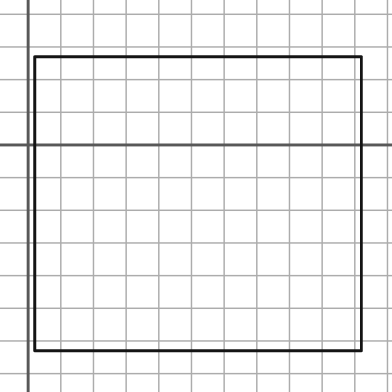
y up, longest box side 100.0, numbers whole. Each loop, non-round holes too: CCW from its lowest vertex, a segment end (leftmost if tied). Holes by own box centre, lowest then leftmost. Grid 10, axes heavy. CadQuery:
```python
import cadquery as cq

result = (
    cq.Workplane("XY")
    .moveTo(2.0, -63.0)
    .lineTo(102.0, -63.0)
    .lineTo(102.0, 27.0)
    .lineTo(2.0, 27.0)
    .close()
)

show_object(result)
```